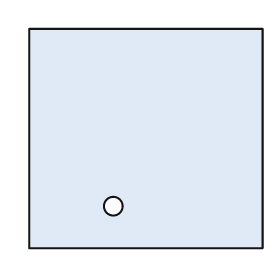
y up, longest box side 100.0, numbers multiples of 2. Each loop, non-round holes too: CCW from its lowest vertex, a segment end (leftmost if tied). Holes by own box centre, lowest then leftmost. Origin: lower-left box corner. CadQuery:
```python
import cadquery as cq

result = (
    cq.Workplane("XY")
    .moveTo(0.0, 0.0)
    .lineTo(100.0, 0.0)
    .lineTo(100.0, 94.0)
    .lineTo(0.0, 94.0)
    .close()
    .moveTo(36.0, 18.0)
    .circle(4.0)
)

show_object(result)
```